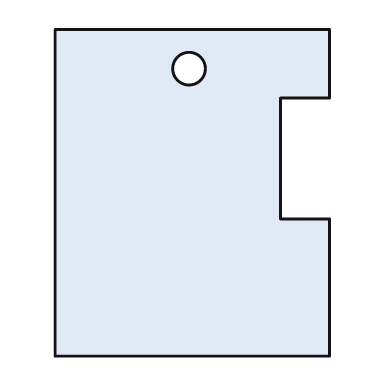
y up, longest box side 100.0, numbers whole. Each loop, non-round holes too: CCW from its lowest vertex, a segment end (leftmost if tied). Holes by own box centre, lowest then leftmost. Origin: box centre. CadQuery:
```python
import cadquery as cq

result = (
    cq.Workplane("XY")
    .moveTo(-42.0, -50.0)
    .lineTo(42.0, -50.0)
    .lineTo(42.0, -8.0)
    .lineTo(27.0, -8.0)
    .lineTo(27.0, 29.0)
    .lineTo(42.0, 29.0)
    .lineTo(42.0, 50.0)
    .lineTo(-42.0, 50.0)
    .close()
    .moveTo(-1.0, 38.0)
    .circle(5.0)
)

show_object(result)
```